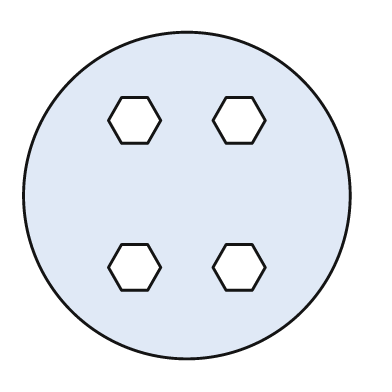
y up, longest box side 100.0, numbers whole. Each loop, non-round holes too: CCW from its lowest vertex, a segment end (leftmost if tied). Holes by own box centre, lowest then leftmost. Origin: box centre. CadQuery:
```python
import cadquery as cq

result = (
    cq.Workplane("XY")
    .moveTo(0.0, 0.0)
    .circle(50.0)
    .moveTo(-20.0, -29.0)
    .lineTo(-12.0, -29.0)
    .lineTo(-8.0, -22.0)
    .lineTo(-12.0, -15.0)
    .lineTo(-20.0, -15.0)
    .lineTo(-24.0, -22.0)
    .close()
    .moveTo(12.0, -29.0)
    .lineTo(20.0, -29.0)
    .lineTo(24.0, -22.0)
    .lineTo(20.0, -15.0)
    .lineTo(12.0, -15.0)
    .lineTo(8.0, -22.0)
    .close()
    .moveTo(-20.0, 16.0)
    .lineTo(-12.0, 16.0)
    .lineTo(-8.0, 23.0)
    .lineTo(-12.0, 30.0)
    .lineTo(-20.0, 30.0)
    .lineTo(-24.0, 23.0)
    .close()
    .moveTo(12.0, 16.0)
    .lineTo(20.0, 16.0)
    .lineTo(24.0, 23.0)
    .lineTo(20.0, 30.0)
    .lineTo(12.0, 30.0)
    .lineTo(8.0, 23.0)
    .close()
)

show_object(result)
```